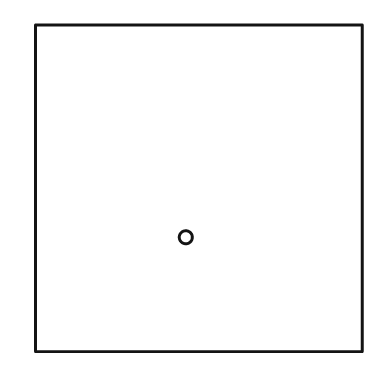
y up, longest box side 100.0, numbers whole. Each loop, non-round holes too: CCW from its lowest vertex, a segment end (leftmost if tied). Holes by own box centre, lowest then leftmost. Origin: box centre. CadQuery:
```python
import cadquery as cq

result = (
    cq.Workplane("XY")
    .moveTo(-50.0, -50.0)
    .lineTo(50.0, -50.0)
    .lineTo(50.0, 50.0)
    .lineTo(-50.0, 50.0)
    .close()
    .moveTo(-4.0, -15.0)
    .circle(2.0)
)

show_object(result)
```